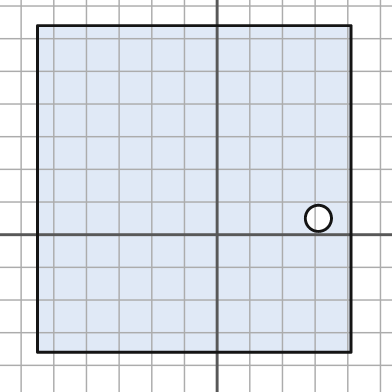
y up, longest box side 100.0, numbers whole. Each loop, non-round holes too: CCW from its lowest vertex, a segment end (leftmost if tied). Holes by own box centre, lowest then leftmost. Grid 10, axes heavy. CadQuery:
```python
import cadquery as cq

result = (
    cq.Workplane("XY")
    .moveTo(-55.0, -36.0)
    .lineTo(41.0, -36.0)
    .lineTo(41.0, 64.0)
    .lineTo(-55.0, 64.0)
    .close()
    .moveTo(31.0, 5.0)
    .circle(4.0)
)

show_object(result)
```